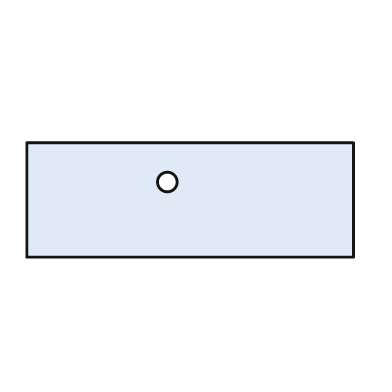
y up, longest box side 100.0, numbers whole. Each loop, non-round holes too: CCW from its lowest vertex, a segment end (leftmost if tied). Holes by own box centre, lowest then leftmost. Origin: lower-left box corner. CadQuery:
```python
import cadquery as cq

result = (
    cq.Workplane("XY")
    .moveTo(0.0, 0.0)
    .lineTo(100.0, 0.0)
    .lineTo(100.0, 35.0)
    .lineTo(0.0, 35.0)
    .close()
    .moveTo(43.0, 23.0)
    .circle(3.0)
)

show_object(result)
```